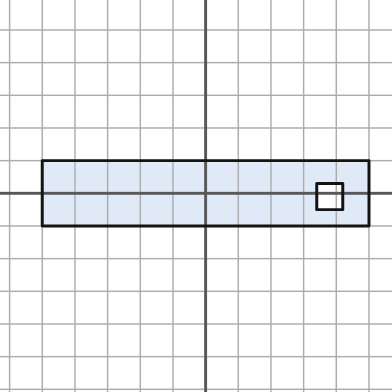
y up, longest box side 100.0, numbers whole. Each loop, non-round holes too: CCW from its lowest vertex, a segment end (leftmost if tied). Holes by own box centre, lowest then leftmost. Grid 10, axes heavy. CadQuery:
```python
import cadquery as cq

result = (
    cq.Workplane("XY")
    .moveTo(-50.0, -10.0)
    .lineTo(50.0, -10.0)
    .lineTo(50.0, 10.0)
    .lineTo(-50.0, 10.0)
    .close()
    .moveTo(34.0, -5.0)
    .lineTo(42.0, -5.0)
    .lineTo(42.0, 3.0)
    .lineTo(34.0, 3.0)
    .close()
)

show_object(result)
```